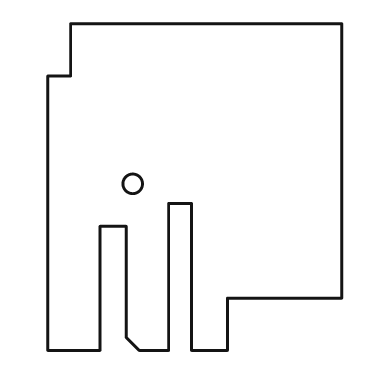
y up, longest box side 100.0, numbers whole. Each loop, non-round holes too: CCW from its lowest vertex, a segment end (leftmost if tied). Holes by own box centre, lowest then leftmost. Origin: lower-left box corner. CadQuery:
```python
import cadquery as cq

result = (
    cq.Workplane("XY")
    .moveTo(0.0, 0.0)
    .lineTo(16.0, 0.0)
    .lineTo(16.0, 38.0)
    .lineTo(24.0, 38.0)
    .lineTo(24.0, 4.0)
    .lineTo(28.0, 0.0)
    .lineTo(37.0, 0.0)
    .lineTo(37.0, 45.0)
    .lineTo(44.0, 45.0)
    .lineTo(44.0, 0.0)
    .lineTo(55.0, 0.0)
    .lineTo(55.0, 16.0)
    .lineTo(90.0, 16.0)
    .lineTo(90.0, 100.0)
    .lineTo(7.0, 100.0)
    .lineTo(7.0, 84.0)
    .lineTo(0.0, 84.0)
    .close()
    .moveTo(26.0, 51.0)
    .circle(3.0)
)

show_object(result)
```